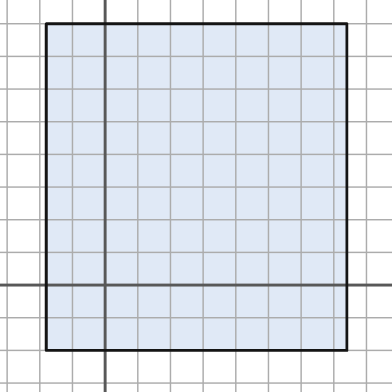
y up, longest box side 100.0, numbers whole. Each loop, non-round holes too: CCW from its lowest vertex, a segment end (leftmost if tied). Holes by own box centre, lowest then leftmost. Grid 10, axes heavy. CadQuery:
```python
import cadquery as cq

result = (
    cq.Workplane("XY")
    .moveTo(-18.0, -20.0)
    .lineTo(74.0, -20.0)
    .lineTo(74.0, 80.0)
    .lineTo(-18.0, 80.0)
    .close()
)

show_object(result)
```